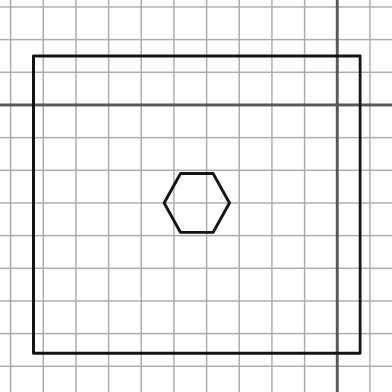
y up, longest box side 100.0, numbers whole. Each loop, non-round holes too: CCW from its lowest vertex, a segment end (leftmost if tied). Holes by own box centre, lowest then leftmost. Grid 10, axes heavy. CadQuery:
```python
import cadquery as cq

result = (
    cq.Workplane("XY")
    .moveTo(-93.0, -76.0)
    .lineTo(7.0, -76.0)
    .lineTo(7.0, 15.0)
    .lineTo(-93.0, 15.0)
    .close()
    .moveTo(-48.0, -39.0)
    .lineTo(-38.0, -39.0)
    .lineTo(-33.0, -30.0)
    .lineTo(-38.0, -21.0)
    .lineTo(-48.0, -21.0)
    .lineTo(-53.0, -30.0)
    .close()
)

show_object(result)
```